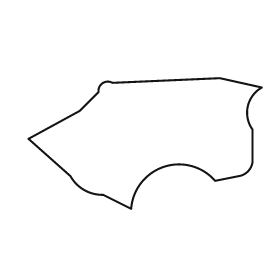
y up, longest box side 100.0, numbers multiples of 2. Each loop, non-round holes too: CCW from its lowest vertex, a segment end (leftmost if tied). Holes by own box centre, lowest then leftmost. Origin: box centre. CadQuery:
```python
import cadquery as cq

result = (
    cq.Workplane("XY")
    .moveTo(-6.0, -28.0)
    .threePointArc((8.0, -10.0), (30.0, -16.0))
    .lineTo(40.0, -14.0)
    .threePointArc((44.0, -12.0), (46.0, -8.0))
    .lineTo(46.0, 6.0)
    .threePointArc((44.0, 16.0), (50.0, 24.0))
    .lineTo(32.0, 28.0)
    .lineTo(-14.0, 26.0)
    .threePointArc((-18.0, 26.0), (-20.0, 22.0))
    .lineTo(-28.0, 14.0)
    .lineTo(-50.0, 2.0)
    .lineTo(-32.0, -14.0)
    .threePointArc((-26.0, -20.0), (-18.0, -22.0))
    .close()
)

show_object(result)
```